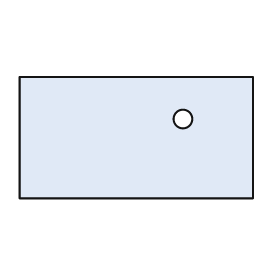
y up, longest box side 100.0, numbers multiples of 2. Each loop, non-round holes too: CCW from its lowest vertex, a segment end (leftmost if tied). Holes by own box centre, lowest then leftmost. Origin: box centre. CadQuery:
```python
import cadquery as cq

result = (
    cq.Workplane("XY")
    .moveTo(-50.0, -26.0)
    .lineTo(50.0, -26.0)
    .lineTo(50.0, 26.0)
    .lineTo(-50.0, 26.0)
    .close()
    .moveTo(20.0, 8.0)
    .circle(4.0)
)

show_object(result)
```